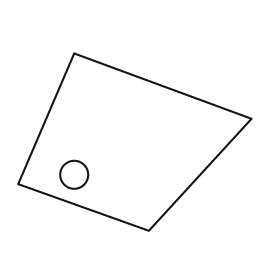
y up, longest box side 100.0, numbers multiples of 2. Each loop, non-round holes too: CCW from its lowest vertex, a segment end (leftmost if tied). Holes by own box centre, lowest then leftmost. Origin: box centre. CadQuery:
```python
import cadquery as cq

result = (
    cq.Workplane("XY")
    .moveTo(6.0, -38.0)
    .lineTo(50.0, 10.0)
    .lineTo(-26.0, 38.0)
    .lineTo(-50.0, -18.0)
    .close()
    .moveTo(-26.0, -14.0)
    .circle(6.0)
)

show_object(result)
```